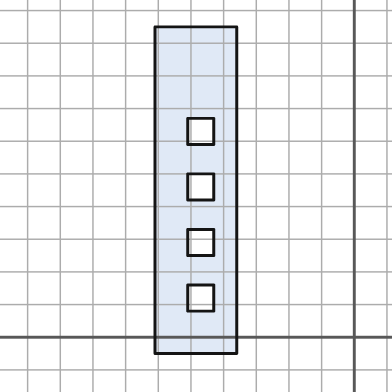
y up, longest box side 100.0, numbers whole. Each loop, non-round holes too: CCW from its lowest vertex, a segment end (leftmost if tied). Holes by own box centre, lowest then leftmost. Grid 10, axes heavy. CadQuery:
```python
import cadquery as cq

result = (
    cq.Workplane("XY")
    .moveTo(-61.0, -5.0)
    .lineTo(-36.0, -5.0)
    .lineTo(-36.0, 95.0)
    .lineTo(-61.0, 95.0)
    .close()
    .moveTo(-51.0, 8.0)
    .lineTo(-43.0, 8.0)
    .lineTo(-43.0, 16.0)
    .lineTo(-51.0, 16.0)
    .close()
    .moveTo(-51.0, 25.0)
    .lineTo(-43.0, 25.0)
    .lineTo(-43.0, 33.0)
    .lineTo(-51.0, 33.0)
    .close()
    .moveTo(-51.0, 42.0)
    .lineTo(-43.0, 42.0)
    .lineTo(-43.0, 50.0)
    .lineTo(-51.0, 50.0)
    .close()
    .moveTo(-51.0, 59.0)
    .lineTo(-43.0, 59.0)
    .lineTo(-43.0, 67.0)
    .lineTo(-51.0, 67.0)
    .close()
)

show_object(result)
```